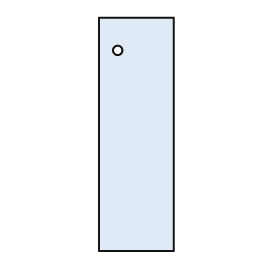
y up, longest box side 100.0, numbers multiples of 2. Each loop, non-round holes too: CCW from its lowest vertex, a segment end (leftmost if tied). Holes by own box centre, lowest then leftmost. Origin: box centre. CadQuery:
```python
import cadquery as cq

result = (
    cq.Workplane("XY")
    .moveTo(-16.0, -50.0)
    .lineTo(16.0, -50.0)
    .lineTo(16.0, 50.0)
    .lineTo(-16.0, 50.0)
    .close()
    .moveTo(-8.0, 36.0)
    .circle(2.0)
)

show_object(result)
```